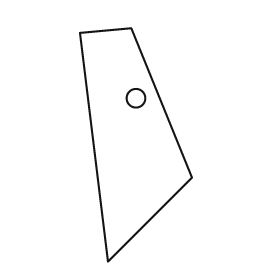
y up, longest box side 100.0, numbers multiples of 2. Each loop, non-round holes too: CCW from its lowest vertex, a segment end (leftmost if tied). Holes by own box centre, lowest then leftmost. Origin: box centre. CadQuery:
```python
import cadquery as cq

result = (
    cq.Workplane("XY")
    .moveTo(-12.0, -50.0)
    .lineTo(24.0, -14.0)
    .lineTo(-2.0, 50.0)
    .lineTo(-24.0, 48.0)
    .close()
    .moveTo(0.0, 20.0)
    .circle(4.0)
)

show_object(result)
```